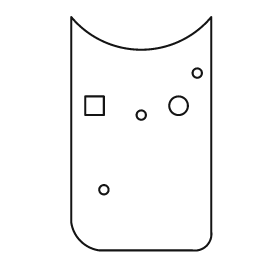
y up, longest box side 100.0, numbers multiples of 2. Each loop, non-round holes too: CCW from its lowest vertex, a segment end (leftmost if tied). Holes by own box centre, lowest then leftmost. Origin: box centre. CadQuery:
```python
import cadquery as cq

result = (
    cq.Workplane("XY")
    .moveTo(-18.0, -50.0)
    .lineTo(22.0, -50.0)
    .threePointArc((28.0, -48.0), (30.0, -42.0))
    .lineTo(30.0, 50.0)
    .threePointArc((0.0, 36.0), (-30.0, 50.0))
    .lineTo(-30.0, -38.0)
    .threePointArc((-26.0, -46.0), (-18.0, -50.0))
    .close()
    .moveTo(-16.0, -24.0)
    .circle(2.0)
    .moveTo(0.0, 8.0)
    .circle(2.0)
    .moveTo(-24.0, 8.0)
    .lineTo(-16.0, 8.0)
    .lineTo(-16.0, 16.0)
    .lineTo(-24.0, 16.0)
    .close()
    .moveTo(16.0, 12.0)
    .circle(4.0)
    .moveTo(24.0, 26.0)
    .circle(2.0)
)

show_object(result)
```